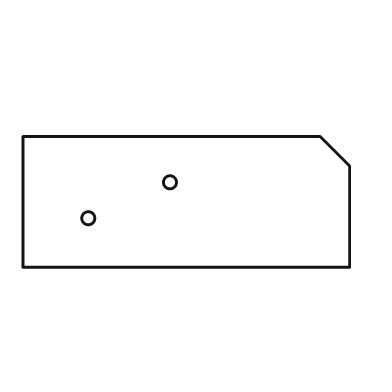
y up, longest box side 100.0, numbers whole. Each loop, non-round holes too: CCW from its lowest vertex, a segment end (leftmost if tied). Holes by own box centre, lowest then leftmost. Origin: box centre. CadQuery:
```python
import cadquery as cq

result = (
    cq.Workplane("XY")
    .moveTo(-50.0, -20.0)
    .lineTo(50.0, -20.0)
    .lineTo(50.0, 11.0)
    .lineTo(41.0, 20.0)
    .lineTo(-50.0, 20.0)
    .close()
    .moveTo(-30.0, -5.0)
    .circle(2.0)
    .moveTo(-5.0, 6.0)
    .circle(2.0)
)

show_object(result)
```